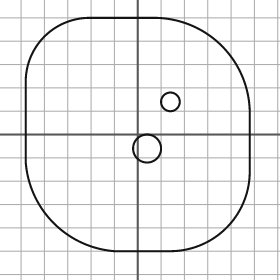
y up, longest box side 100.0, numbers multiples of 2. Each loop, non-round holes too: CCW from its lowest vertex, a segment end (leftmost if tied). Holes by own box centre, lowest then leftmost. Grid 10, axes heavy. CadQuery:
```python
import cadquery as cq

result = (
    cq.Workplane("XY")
    .moveTo(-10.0, -50.0)
    .lineTo(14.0, -50.0)
    .threePointArc((38.0, -40.0), (48.0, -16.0))
    .lineTo(48.0, 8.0)
    .threePointArc((36.0, 38.0), (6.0, 50.0))
    .lineTo(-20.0, 50.0)
    .threePointArc((-40.0, 42.0), (-48.0, 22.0))
    .lineTo(-48.0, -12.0)
    .threePointArc((-36.0, -38.0), (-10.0, -50.0))
    .close()
    .moveTo(4.0, -6.0)
    .circle(6.0)
    .moveTo(14.0, 14.0)
    .circle(4.0)
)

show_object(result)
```